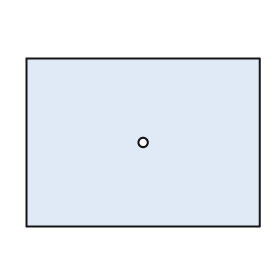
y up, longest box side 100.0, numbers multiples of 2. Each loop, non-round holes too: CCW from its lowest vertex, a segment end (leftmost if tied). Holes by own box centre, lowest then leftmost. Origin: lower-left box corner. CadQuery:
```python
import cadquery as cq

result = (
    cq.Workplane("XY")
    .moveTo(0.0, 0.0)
    .lineTo(100.0, 0.0)
    .lineTo(100.0, 72.0)
    .lineTo(0.0, 72.0)
    .close()
    .moveTo(50.0, 36.0)
    .circle(2.0)
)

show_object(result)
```